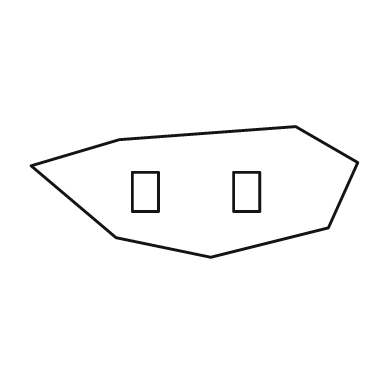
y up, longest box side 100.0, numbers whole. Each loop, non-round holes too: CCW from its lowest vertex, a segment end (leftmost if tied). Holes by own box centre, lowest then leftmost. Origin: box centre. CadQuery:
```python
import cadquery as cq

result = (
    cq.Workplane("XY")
    .moveTo(5.0, -20.0)
    .lineTo(41.0, -11.0)
    .lineTo(50.0, 9.0)
    .lineTo(31.0, 20.0)
    .lineTo(-23.0, 16.0)
    .lineTo(-50.0, 8.0)
    .lineTo(-24.0, -14.0)
    .close()
    .moveTo(-19.0, -6.0)
    .lineTo(-11.0, -6.0)
    .lineTo(-11.0, 6.0)
    .lineTo(-19.0, 6.0)
    .close()
    .moveTo(12.0, -6.0)
    .lineTo(20.0, -6.0)
    .lineTo(20.0, 6.0)
    .lineTo(12.0, 6.0)
    .close()
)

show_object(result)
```